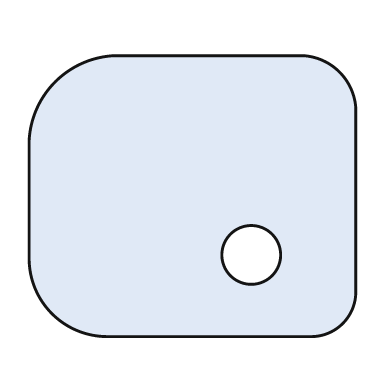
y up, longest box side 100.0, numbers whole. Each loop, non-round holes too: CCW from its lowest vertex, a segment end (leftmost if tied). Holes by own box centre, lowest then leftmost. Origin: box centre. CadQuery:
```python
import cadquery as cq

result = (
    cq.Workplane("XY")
    .moveTo(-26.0, -43.0)
    .lineTo(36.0, -43.0)
    .threePointArc((46.0, -39.0), (50.0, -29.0))
    .lineTo(50.0, 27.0)
    .threePointArc((45.0, 38.0), (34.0, 43.0))
    .lineTo(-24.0, 43.0)
    .threePointArc((-42.0, 35.0), (-50.0, 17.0))
    .lineTo(-50.0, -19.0)
    .threePointArc((-43.0, -36.0), (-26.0, -43.0))
    .close()
    .moveTo(18.0, -18.0)
    .circle(9.0)
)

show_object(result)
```